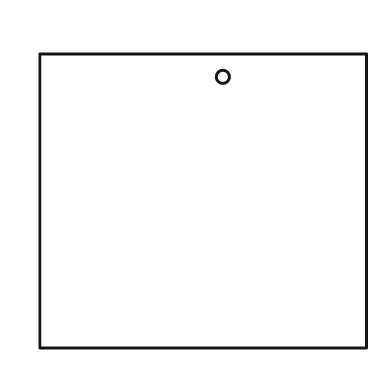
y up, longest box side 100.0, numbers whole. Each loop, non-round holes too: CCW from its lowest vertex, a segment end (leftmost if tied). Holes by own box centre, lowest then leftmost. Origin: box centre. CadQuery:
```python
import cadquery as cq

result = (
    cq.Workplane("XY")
    .moveTo(-50.0, -45.0)
    .lineTo(50.0, -45.0)
    .lineTo(50.0, 45.0)
    .lineTo(-50.0, 45.0)
    .close()
    .moveTo(6.0, 38.0)
    .circle(2.0)
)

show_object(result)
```